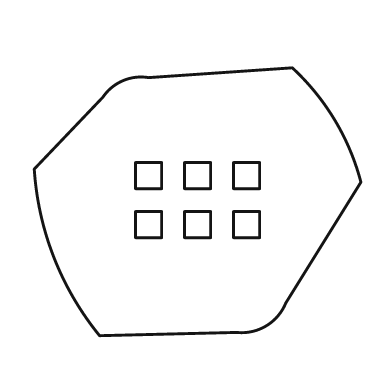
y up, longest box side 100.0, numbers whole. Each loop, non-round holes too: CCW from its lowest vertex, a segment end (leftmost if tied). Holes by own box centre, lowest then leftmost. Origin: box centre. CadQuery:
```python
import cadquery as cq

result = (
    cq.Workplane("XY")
    .moveTo(-30.0, -41.0)
    .lineTo(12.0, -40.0)
    .threePointArc((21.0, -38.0), (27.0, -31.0))
    .lineTo(50.0, 6.0)
    .threePointArc((42.0, 25.0), (29.0, 41.0))
    .lineTo(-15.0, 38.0)
    .threePointArc((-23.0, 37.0), (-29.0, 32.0))
    .lineTo(-50.0, 10.0)
    .threePointArc((-44.0, -17.0), (-30.0, -41.0))
    .close()
    .moveTo(-19.0, -11.0)
    .lineTo(-11.0, -11.0)
    .lineTo(-11.0, -3.0)
    .lineTo(-19.0, -3.0)
    .close()
    .moveTo(-4.0, -11.0)
    .lineTo(4.0, -11.0)
    .lineTo(4.0, -3.0)
    .lineTo(-4.0, -3.0)
    .close()
    .moveTo(11.0, -11.0)
    .lineTo(19.0, -11.0)
    .lineTo(19.0, -3.0)
    .lineTo(11.0, -3.0)
    .close()
    .moveTo(-19.0, 4.0)
    .lineTo(-11.0, 4.0)
    .lineTo(-11.0, 12.0)
    .lineTo(-19.0, 12.0)
    .close()
    .moveTo(-4.0, 4.0)
    .lineTo(4.0, 4.0)
    .lineTo(4.0, 12.0)
    .lineTo(-4.0, 12.0)
    .close()
    .moveTo(11.0, 4.0)
    .lineTo(19.0, 4.0)
    .lineTo(19.0, 12.0)
    .lineTo(11.0, 12.0)
    .close()
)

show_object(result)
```